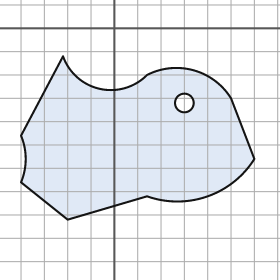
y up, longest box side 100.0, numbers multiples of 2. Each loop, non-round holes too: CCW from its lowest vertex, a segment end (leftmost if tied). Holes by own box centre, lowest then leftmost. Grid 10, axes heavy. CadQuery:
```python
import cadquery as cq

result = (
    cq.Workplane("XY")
    .moveTo(-20.0, -82.0)
    .lineTo(14.0, -72.0)
    .threePointArc((40.0, -72.0), (60.0, -56.0))
    .lineTo(50.0, -30.0)
    .threePointArc((34.0, -18.0), (14.0, -20.0))
    .threePointArc((-6.0, -26.0), (-22.0, -12.0))
    .lineTo(-40.0, -46.0)
    .threePointArc((-38.0, -56.0), (-40.0, -66.0))
    .close()
    .moveTo(30.0, -32.0)
    .circle(4.0)
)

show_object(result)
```